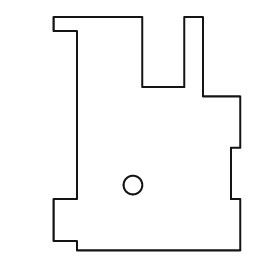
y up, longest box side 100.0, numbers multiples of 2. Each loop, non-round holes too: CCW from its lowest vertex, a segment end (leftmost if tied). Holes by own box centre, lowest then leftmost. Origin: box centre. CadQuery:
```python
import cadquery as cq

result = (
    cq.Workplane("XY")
    .moveTo(-30.0, -50.0)
    .lineTo(40.0, -50.0)
    .lineTo(40.0, -28.0)
    .lineTo(36.0, -28.0)
    .lineTo(36.0, -6.0)
    .lineTo(40.0, -6.0)
    .lineTo(40.0, 16.0)
    .lineTo(24.0, 16.0)
    .lineTo(24.0, 50.0)
    .lineTo(16.0, 50.0)
    .lineTo(16.0, 20.0)
    .lineTo(-2.0, 20.0)
    .lineTo(-2.0, 50.0)
    .lineTo(-40.0, 50.0)
    .lineTo(-40.0, 44.0)
    .lineTo(-30.0, 44.0)
    .lineTo(-30.0, -28.0)
    .lineTo(-40.0, -28.0)
    .lineTo(-40.0, -46.0)
    .lineTo(-30.0, -46.0)
    .close()
    .moveTo(-6.0, -22.0)
    .circle(4.0)
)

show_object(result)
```